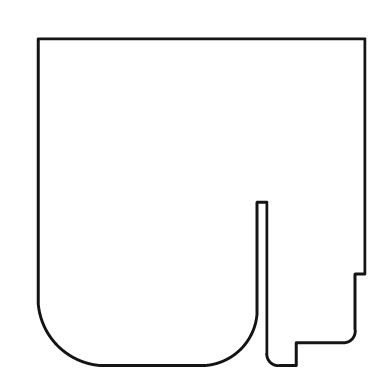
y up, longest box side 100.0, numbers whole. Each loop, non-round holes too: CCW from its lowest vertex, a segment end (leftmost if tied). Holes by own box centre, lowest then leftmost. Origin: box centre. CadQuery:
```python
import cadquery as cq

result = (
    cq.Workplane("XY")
    .moveTo(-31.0, -50.0)
    .lineTo(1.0, -50.0)
    .threePointArc((12.0, -45.0), (17.0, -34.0))
    .lineTo(17.0, 0.0)
    .lineTo(20.0, 0.0)
    .lineTo(20.0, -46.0)
    .threePointArc((21.0, -49.0), (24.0, -50.0))
    .lineTo(29.0, -50.0)
    .lineTo(29.0, -43.0)
    .lineTo(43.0, -43.0)
    .threePointArc((46.0, -42.0), (47.0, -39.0))
    .lineTo(47.0, -22.0)
    .lineTo(50.0, -22.0)
    .lineTo(50.0, 50.0)
    .lineTo(-50.0, 50.0)
    .lineTo(-50.0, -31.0)
    .threePointArc((-44.0, -44.0), (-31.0, -50.0))
    .close()
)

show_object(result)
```